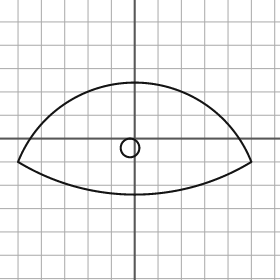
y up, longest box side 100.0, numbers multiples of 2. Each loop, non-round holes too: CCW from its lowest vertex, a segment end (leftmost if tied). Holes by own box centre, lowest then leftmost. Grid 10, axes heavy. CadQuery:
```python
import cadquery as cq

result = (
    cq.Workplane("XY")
    .moveTo(-50.0, -10.0)
    .threePointArc((0.0, -24.0), (50.0, -10.0))
    .threePointArc((0.0, 24.0), (-50.0, -10.0))
    .close()
    .moveTo(-2.0, -4.0)
    .circle(4.0)
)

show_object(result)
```